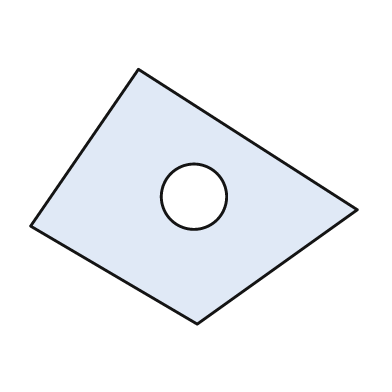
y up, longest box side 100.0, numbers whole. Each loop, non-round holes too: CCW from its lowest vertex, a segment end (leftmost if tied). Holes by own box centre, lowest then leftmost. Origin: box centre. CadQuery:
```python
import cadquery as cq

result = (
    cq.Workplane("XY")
    .moveTo(1.0, -39.0)
    .lineTo(50.0, -4.0)
    .lineTo(-17.0, 39.0)
    .lineTo(-50.0, -9.0)
    .close()
    .moveTo(0.0, 0.0)
    .circle(10.0)
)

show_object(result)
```